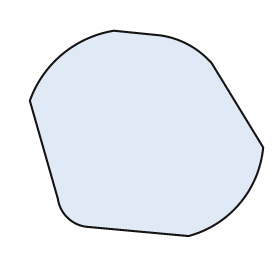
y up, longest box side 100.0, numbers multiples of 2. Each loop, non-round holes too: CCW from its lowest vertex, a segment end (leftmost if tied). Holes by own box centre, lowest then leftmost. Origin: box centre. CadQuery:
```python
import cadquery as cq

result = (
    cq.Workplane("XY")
    .moveTo(18.0, -44.0)
    .threePointArc((40.0, -30.0), (50.0, -6.0))
    .lineTo(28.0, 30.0)
    .threePointArc((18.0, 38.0), (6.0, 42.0))
    .lineTo(-14.0, 44.0)
    .threePointArc((-36.0, 34.0), (-50.0, 14.0))
    .lineTo(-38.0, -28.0)
    .threePointArc((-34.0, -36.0), (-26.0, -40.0))
    .close()
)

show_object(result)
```